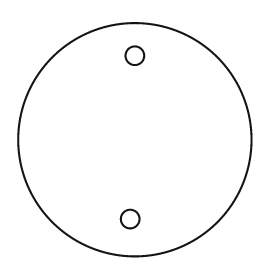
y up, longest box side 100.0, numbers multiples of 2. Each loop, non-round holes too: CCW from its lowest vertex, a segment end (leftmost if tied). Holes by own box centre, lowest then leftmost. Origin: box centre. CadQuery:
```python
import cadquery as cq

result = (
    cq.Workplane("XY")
    .moveTo(0.0, 0.0)
    .circle(50.0)
    .moveTo(-2.0, -34.0)
    .circle(4.0)
    .moveTo(0.0, 36.0)
    .circle(4.0)
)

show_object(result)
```